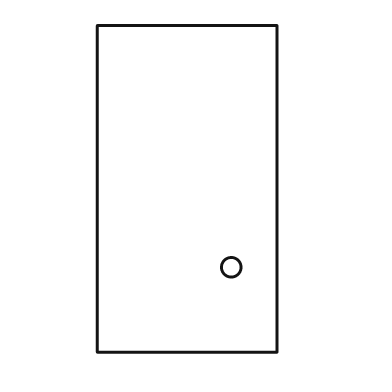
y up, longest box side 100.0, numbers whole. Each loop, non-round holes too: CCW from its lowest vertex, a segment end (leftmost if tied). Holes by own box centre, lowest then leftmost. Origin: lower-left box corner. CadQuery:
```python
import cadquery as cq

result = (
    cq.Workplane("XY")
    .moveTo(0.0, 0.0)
    .lineTo(55.0, 0.0)
    .lineTo(55.0, 100.0)
    .lineTo(0.0, 100.0)
    .close()
    .moveTo(41.0, 26.0)
    .circle(3.0)
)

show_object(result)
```